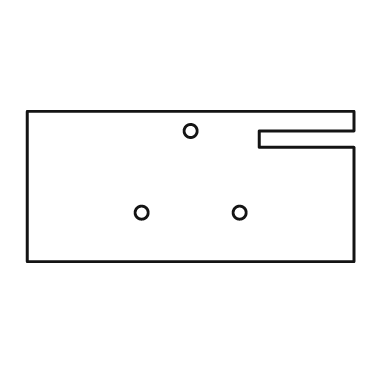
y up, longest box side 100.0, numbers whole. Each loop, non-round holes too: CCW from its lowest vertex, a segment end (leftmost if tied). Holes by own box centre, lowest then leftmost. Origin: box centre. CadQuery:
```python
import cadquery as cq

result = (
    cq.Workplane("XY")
    .moveTo(-50.0, -23.0)
    .lineTo(50.0, -23.0)
    .lineTo(50.0, 12.0)
    .lineTo(21.0, 12.0)
    .lineTo(21.0, 17.0)
    .lineTo(50.0, 17.0)
    .lineTo(50.0, 23.0)
    .lineTo(-50.0, 23.0)
    .close()
    .moveTo(-15.0, -8.0)
    .circle(2.0)
    .moveTo(15.0, -8.0)
    .circle(2.0)
    .moveTo(0.0, 17.0)
    .circle(2.0)
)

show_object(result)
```